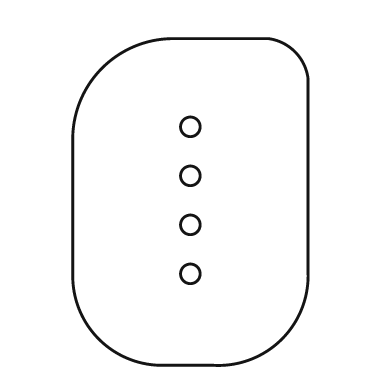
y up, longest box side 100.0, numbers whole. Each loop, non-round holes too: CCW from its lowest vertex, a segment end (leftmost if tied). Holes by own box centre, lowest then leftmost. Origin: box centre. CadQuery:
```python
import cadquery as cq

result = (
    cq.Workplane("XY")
    .moveTo(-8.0, -50.0)
    .lineTo(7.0, -50.0)
    .threePointArc((28.0, -42.0), (36.0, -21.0))
    .lineTo(36.0, 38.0)
    .threePointArc((32.0, 46.0), (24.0, 50.0))
    .lineTo(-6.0, 50.0)
    .threePointArc((-27.0, 41.0), (-36.0, 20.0))
    .lineTo(-36.0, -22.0)
    .threePointArc((-28.0, -42.0), (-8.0, -50.0))
    .close()
    .moveTo(0.0, -22.0)
    .circle(3.0)
    .moveTo(0.0, -7.0)
    .circle(3.0)
    .moveTo(0.0, 8.0)
    .circle(3.0)
    .moveTo(0.0, 23.0)
    .circle(3.0)
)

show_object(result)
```